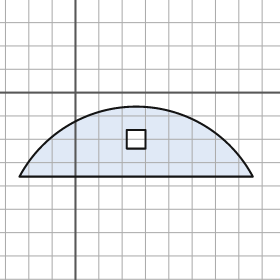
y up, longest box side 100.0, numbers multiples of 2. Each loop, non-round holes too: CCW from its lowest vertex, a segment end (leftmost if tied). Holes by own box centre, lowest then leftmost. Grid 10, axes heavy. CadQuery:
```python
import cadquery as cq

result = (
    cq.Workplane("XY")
    .moveTo(-24.0, -36.0)
    .lineTo(76.0, -36.0)
    .threePointArc((26.0, -6.0), (-24.0, -36.0))
    .close()
    .moveTo(22.0, -24.0)
    .lineTo(30.0, -24.0)
    .lineTo(30.0, -16.0)
    .lineTo(22.0, -16.0)
    .close()
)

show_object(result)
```